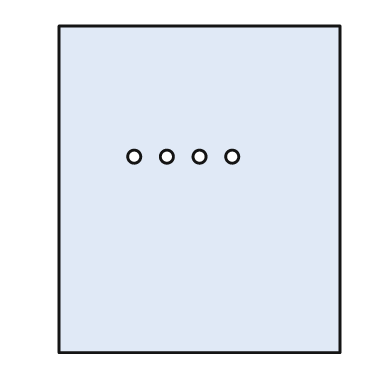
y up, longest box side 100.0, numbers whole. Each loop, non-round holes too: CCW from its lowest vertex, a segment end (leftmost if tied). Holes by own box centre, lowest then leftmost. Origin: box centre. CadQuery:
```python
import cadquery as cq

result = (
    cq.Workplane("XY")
    .moveTo(-43.0, -50.0)
    .lineTo(43.0, -50.0)
    .lineTo(43.0, 50.0)
    .lineTo(-43.0, 50.0)
    .close()
    .moveTo(-20.0, 10.0)
    .circle(2.0)
    .moveTo(-10.0, 10.0)
    .circle(2.0)
    .moveTo(0.0, 10.0)
    .circle(2.0)
    .moveTo(10.0, 10.0)
    .circle(2.0)
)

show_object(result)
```